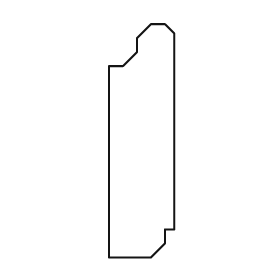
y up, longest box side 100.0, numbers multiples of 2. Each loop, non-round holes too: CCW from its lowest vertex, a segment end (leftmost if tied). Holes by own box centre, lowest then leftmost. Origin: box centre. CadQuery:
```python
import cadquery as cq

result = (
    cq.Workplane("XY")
    .moveTo(-14.0, -50.0)
    .lineTo(4.0, -50.0)
    .lineTo(10.0, -44.0)
    .lineTo(10.0, -38.0)
    .lineTo(14.0, -38.0)
    .lineTo(14.0, 46.0)
    .lineTo(10.0, 50.0)
    .lineTo(4.0, 50.0)
    .lineTo(-2.0, 44.0)
    .lineTo(-2.0, 38.0)
    .lineTo(-8.0, 32.0)
    .lineTo(-14.0, 32.0)
    .close()
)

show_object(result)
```